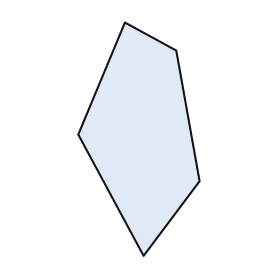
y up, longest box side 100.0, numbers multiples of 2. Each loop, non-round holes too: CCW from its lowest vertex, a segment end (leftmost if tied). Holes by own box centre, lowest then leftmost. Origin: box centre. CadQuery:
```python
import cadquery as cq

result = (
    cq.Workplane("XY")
    .moveTo(2.0, -50.0)
    .lineTo(26.0, -18.0)
    .lineTo(16.0, 38.0)
    .lineTo(-6.0, 50.0)
    .lineTo(-26.0, 2.0)
    .close()
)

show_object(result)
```